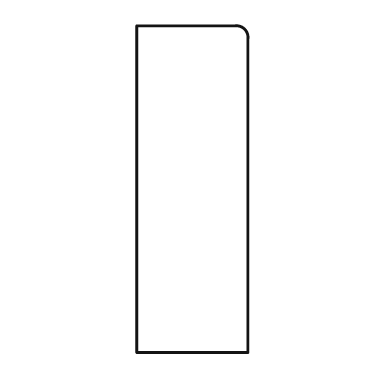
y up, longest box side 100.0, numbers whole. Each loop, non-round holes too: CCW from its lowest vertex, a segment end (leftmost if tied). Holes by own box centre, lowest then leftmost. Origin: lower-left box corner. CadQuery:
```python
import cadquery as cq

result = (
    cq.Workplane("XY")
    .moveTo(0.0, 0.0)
    .lineTo(34.0, 0.0)
    .lineTo(34.0, 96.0)
    .threePointArc((33.0, 99.0), (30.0, 100.0))
    .lineTo(0.0, 100.0)
    .close()
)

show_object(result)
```